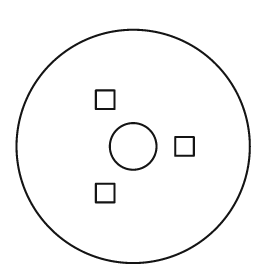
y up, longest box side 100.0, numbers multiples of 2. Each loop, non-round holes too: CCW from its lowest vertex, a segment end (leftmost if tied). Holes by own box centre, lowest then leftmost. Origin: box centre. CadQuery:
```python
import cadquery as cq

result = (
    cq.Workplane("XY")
    .moveTo(0.0, 0.0)
    .circle(50.0)
    .moveTo(-16.0, -24.0)
    .lineTo(-8.0, -24.0)
    .lineTo(-8.0, -16.0)
    .lineTo(-16.0, -16.0)
    .close()
    .moveTo(0.0, 0.0)
    .circle(10.0)
    .moveTo(18.0, -4.0)
    .lineTo(26.0, -4.0)
    .lineTo(26.0, 4.0)
    .lineTo(18.0, 4.0)
    .close()
    .moveTo(-16.0, 16.0)
    .lineTo(-8.0, 16.0)
    .lineTo(-8.0, 24.0)
    .lineTo(-16.0, 24.0)
    .close()
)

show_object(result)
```